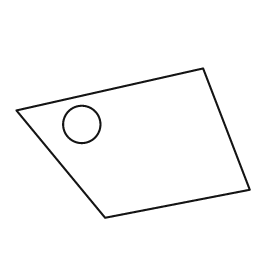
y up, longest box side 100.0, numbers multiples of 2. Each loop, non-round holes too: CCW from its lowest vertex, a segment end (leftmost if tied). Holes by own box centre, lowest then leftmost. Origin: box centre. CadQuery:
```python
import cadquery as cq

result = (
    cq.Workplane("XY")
    .moveTo(-12.0, -32.0)
    .lineTo(50.0, -20.0)
    .lineTo(30.0, 32.0)
    .lineTo(-50.0, 14.0)
    .close()
    .moveTo(-22.0, 8.0)
    .circle(8.0)
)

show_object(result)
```